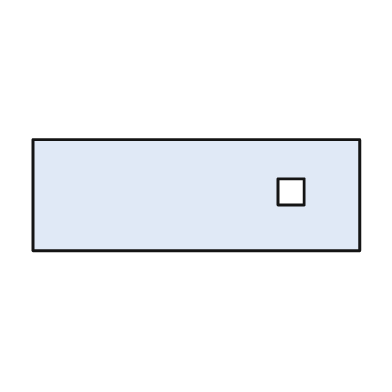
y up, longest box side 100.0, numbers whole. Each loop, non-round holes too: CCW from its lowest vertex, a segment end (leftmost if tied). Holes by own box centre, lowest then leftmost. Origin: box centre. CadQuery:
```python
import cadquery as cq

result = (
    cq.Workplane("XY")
    .moveTo(-50.0, -17.0)
    .lineTo(50.0, -17.0)
    .lineTo(50.0, 17.0)
    .lineTo(-50.0, 17.0)
    .close()
    .moveTo(25.0, -3.0)
    .lineTo(33.0, -3.0)
    .lineTo(33.0, 5.0)
    .lineTo(25.0, 5.0)
    .close()
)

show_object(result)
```